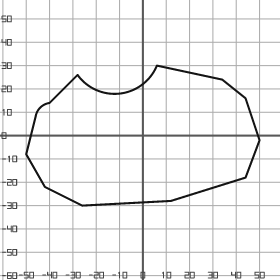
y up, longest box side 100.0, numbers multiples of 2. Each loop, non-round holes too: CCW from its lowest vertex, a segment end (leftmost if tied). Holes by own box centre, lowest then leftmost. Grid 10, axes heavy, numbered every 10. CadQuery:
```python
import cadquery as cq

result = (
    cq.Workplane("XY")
    .moveTo(-26.0, -30.0)
    .lineTo(12.0, -28.0)
    .lineTo(44.0, -18.0)
    .lineTo(50.0, -2.0)
    .lineTo(44.0, 16.0)
    .lineTo(34.0, 24.0)
    .lineTo(6.0, 30.0)
    .threePointArc((-10.0, 18.0), (-28.0, 26.0))
    .lineTo(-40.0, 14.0)
    .threePointArc((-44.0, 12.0), (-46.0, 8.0))
    .lineTo(-50.0, -8.0)
    .lineTo(-42.0, -22.0)
    .close()
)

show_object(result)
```